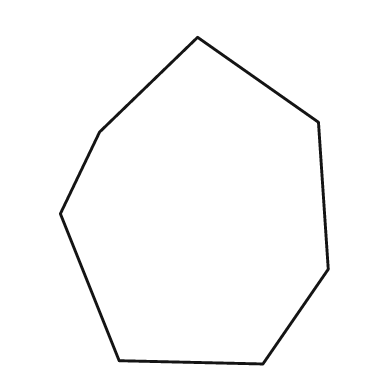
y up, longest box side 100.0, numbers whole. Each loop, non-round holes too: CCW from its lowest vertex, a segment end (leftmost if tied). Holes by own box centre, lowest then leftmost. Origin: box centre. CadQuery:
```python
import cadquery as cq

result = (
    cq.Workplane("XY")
    .moveTo(21.0, -50.0)
    .lineTo(41.0, -21.0)
    .lineTo(38.0, 24.0)
    .lineTo(1.0, 50.0)
    .lineTo(-29.0, 21.0)
    .lineTo(-41.0, -4.0)
    .lineTo(-23.0, -49.0)
    .close()
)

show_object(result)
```